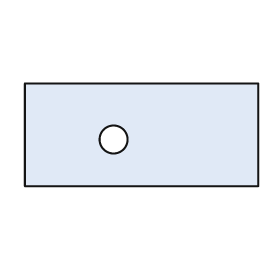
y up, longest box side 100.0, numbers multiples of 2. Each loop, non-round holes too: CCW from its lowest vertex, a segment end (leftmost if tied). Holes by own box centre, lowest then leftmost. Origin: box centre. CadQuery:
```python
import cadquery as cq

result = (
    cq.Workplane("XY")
    .moveTo(-50.0, -22.0)
    .lineTo(50.0, -22.0)
    .lineTo(50.0, 22.0)
    .lineTo(-50.0, 22.0)
    .close()
    .moveTo(-12.0, -2.0)
    .circle(6.0)
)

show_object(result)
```